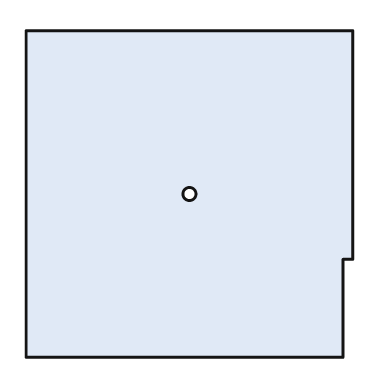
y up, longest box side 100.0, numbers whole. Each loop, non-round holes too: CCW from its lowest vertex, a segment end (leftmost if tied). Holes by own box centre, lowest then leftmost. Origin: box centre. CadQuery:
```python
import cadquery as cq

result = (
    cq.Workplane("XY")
    .moveTo(-50.0, -50.0)
    .lineTo(47.0, -50.0)
    .lineTo(47.0, -20.0)
    .lineTo(50.0, -20.0)
    .lineTo(50.0, 50.0)
    .lineTo(-50.0, 50.0)
    .close()
    .moveTo(0.0, 0.0)
    .circle(2.0)
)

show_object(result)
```